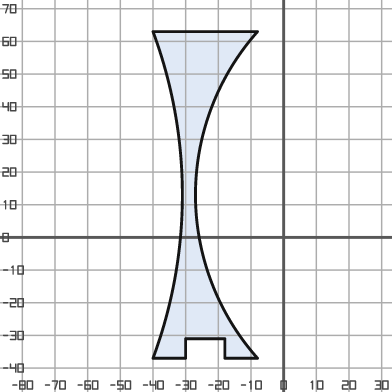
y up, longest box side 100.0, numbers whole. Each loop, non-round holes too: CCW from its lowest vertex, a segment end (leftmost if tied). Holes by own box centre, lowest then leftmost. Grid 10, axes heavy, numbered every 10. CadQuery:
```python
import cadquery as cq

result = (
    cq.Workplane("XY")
    .moveTo(-40.0, -37.0)
    .lineTo(-30.0, -37.0)
    .lineTo(-30.0, -31.0)
    .lineTo(-18.0, -31.0)
    .lineTo(-18.0, -37.0)
    .lineTo(-8.0, -37.0)
    .threePointArc((-27.0, 13.0), (-8.0, 63.0))
    .lineTo(-40.0, 63.0)
    .threePointArc((-31.0, 13.0), (-40.0, -37.0))
    .close()
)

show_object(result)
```